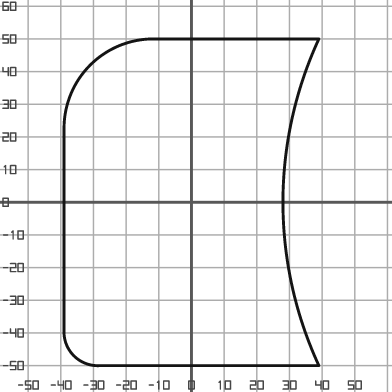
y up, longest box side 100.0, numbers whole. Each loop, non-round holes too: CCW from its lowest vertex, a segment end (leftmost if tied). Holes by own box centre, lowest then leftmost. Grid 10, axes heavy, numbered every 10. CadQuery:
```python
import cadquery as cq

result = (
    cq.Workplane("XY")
    .moveTo(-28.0, -50.0)
    .lineTo(39.0, -50.0)
    .threePointArc((28.0, 0.0), (39.0, 50.0))
    .lineTo(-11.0, 50.0)
    .threePointArc((-31.0, 42.0), (-39.0, 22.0))
    .lineTo(-39.0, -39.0)
    .threePointArc((-36.0, -47.0), (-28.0, -50.0))
    .close()
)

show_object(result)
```